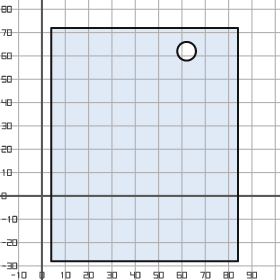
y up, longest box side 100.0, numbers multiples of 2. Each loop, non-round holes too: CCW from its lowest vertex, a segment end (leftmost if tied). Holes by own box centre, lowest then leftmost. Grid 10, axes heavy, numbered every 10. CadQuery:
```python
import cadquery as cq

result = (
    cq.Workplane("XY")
    .moveTo(4.0, -28.0)
    .lineTo(84.0, -28.0)
    .lineTo(84.0, 72.0)
    .lineTo(4.0, 72.0)
    .close()
    .moveTo(62.0, 62.0)
    .circle(4.0)
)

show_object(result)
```